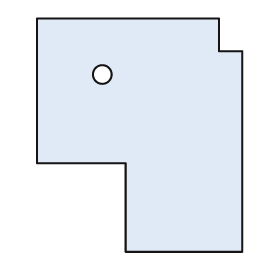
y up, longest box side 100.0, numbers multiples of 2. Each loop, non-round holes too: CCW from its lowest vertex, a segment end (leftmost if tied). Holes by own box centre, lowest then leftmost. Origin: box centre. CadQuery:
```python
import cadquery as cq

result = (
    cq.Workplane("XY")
    .moveTo(-6.0, -50.0)
    .lineTo(44.0, -50.0)
    .lineTo(44.0, 36.0)
    .lineTo(34.0, 36.0)
    .lineTo(34.0, 50.0)
    .lineTo(-44.0, 50.0)
    .lineTo(-44.0, -12.0)
    .lineTo(-6.0, -12.0)
    .close()
    .moveTo(-16.0, 26.0)
    .circle(4.0)
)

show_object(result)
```